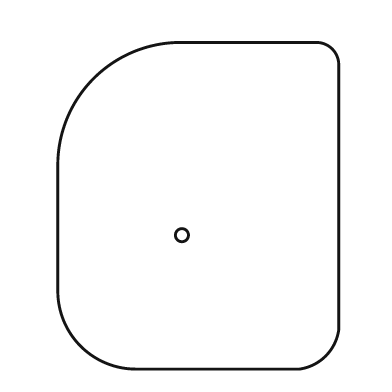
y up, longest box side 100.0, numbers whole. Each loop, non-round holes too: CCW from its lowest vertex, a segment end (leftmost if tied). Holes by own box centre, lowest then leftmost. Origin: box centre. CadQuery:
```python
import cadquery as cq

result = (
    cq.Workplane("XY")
    .moveTo(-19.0, -50.0)
    .lineTo(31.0, -50.0)
    .threePointArc((39.0, -46.0), (43.0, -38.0))
    .lineTo(43.0, 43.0)
    .threePointArc((41.0, 48.0), (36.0, 50.0))
    .lineTo(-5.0, 50.0)
    .threePointArc((-32.0, 39.0), (-43.0, 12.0))
    .lineTo(-43.0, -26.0)
    .threePointArc((-36.0, -43.0), (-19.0, -50.0))
    .close()
    .moveTo(-5.0, -9.0)
    .circle(2.0)
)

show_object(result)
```